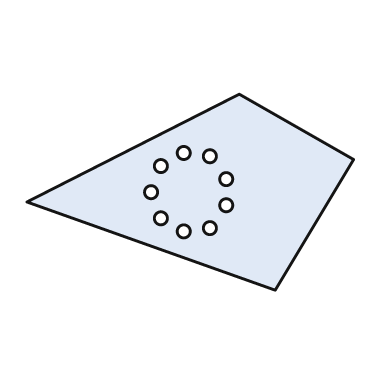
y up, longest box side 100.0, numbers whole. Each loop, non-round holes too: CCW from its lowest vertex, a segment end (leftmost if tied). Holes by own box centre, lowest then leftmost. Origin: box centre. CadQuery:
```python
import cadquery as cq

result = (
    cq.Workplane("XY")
    .moveTo(26.0, -30.0)
    .lineTo(50.0, 10.0)
    .lineTo(15.0, 30.0)
    .lineTo(-50.0, -3.0)
    .close()
    .moveTo(-2.0, -12.0)
    .circle(2.0)
    .moveTo(6.0, -11.0)
    .circle(2.0)
    .moveTo(-9.0, -8.0)
    .circle(2.0)
    .moveTo(11.0, -4.0)
    .circle(2.0)
    .moveTo(-12.0, 0.0)
    .circle(2.0)
    .moveTo(11.0, 4.0)
    .circle(2.0)
    .moveTo(-9.0, 8.0)
    .circle(2.0)
    .moveTo(6.0, 11.0)
    .circle(2.0)
    .moveTo(-2.0, 12.0)
    .circle(2.0)
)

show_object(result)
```